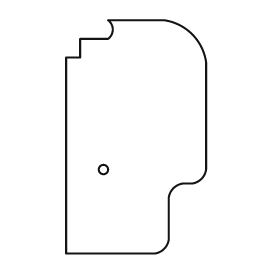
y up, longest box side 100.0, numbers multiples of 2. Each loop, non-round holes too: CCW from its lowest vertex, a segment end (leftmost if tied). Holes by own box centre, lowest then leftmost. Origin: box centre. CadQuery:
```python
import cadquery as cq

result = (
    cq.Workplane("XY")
    .moveTo(-30.0, -50.0)
    .lineTo(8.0, -50.0)
    .threePointArc((12.0, -48.0), (14.0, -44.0))
    .lineTo(14.0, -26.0)
    .threePointArc((16.0, -22.0), (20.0, -20.0))
    .lineTo(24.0, -20.0)
    .threePointArc((28.0, -18.0), (30.0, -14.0))
    .lineTo(30.0, 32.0)
    .threePointArc((24.0, 44.0), (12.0, 50.0))
    .lineTo(-12.0, 50.0)
    .threePointArc((-10.0, 46.0), (-12.0, 42.0))
    .lineTo(-24.0, 42.0)
    .lineTo(-24.0, 34.0)
    .lineTo(-30.0, 34.0)
    .close()
    .moveTo(-14.0, -14.0)
    .circle(2.0)
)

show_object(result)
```